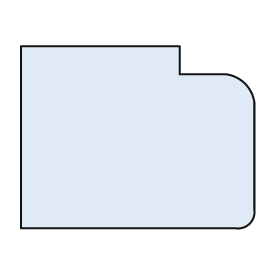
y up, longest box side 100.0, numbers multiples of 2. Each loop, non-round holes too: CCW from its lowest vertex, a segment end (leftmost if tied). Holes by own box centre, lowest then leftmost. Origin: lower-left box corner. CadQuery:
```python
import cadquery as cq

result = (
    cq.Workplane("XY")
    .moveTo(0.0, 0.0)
    .lineTo(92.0, 0.0)
    .threePointArc((98.0, 2.0), (100.0, 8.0))
    .lineTo(100.0, 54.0)
    .threePointArc((96.0, 62.0), (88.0, 66.0))
    .lineTo(68.0, 66.0)
    .lineTo(68.0, 78.0)
    .lineTo(0.0, 78.0)
    .close()
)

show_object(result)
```